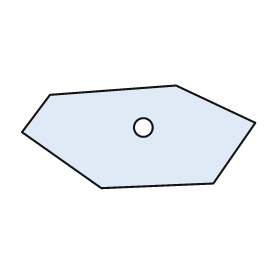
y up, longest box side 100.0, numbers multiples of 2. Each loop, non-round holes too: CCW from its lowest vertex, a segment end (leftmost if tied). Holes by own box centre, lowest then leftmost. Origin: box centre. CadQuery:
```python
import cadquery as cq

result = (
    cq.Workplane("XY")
    .moveTo(-16.0, -22.0)
    .lineTo(32.0, -20.0)
    .lineTo(50.0, 6.0)
    .lineTo(16.0, 22.0)
    .lineTo(-38.0, 18.0)
    .lineTo(-50.0, 2.0)
    .close()
    .moveTo(2.0, 4.0)
    .circle(4.0)
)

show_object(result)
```